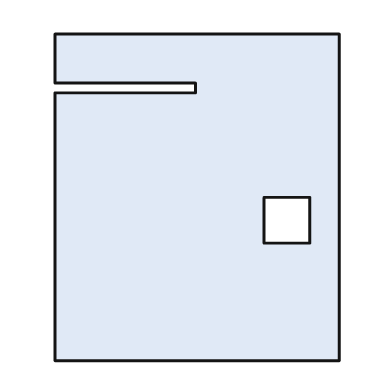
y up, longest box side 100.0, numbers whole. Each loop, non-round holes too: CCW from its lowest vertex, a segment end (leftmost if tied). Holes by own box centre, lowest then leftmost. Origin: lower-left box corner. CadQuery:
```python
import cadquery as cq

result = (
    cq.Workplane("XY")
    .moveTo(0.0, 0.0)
    .lineTo(87.0, 0.0)
    .lineTo(87.0, 100.0)
    .lineTo(0.0, 100.0)
    .lineTo(0.0, 85.0)
    .lineTo(43.0, 85.0)
    .lineTo(43.0, 82.0)
    .lineTo(0.0, 82.0)
    .close()
    .moveTo(64.0, 36.0)
    .lineTo(78.0, 36.0)
    .lineTo(78.0, 50.0)
    .lineTo(64.0, 50.0)
    .close()
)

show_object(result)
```